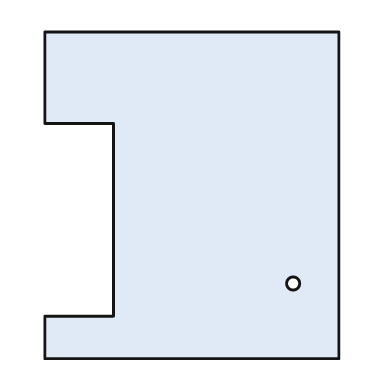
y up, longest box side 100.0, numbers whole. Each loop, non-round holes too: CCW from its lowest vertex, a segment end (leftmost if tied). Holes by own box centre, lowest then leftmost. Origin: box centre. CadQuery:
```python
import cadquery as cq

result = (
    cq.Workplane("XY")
    .moveTo(-45.0, -50.0)
    .lineTo(45.0, -50.0)
    .lineTo(45.0, 50.0)
    .lineTo(-45.0, 50.0)
    .lineTo(-45.0, 22.0)
    .lineTo(-24.0, 22.0)
    .lineTo(-24.0, -37.0)
    .lineTo(-45.0, -37.0)
    .close()
    .moveTo(31.0, -27.0)
    .circle(2.0)
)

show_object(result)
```